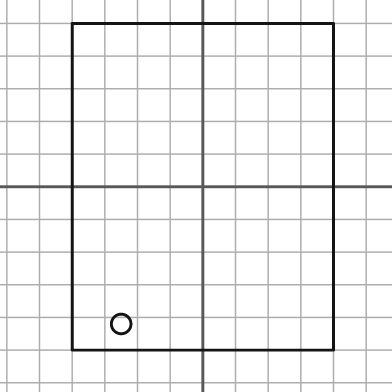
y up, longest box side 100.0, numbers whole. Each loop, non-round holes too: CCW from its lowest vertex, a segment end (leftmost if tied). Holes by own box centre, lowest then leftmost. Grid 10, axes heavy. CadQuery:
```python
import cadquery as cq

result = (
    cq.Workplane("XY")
    .moveTo(-40.0, -50.0)
    .lineTo(40.0, -50.0)
    .lineTo(40.0, 50.0)
    .lineTo(-40.0, 50.0)
    .close()
    .moveTo(-25.0, -42.0)
    .circle(3.0)
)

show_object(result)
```